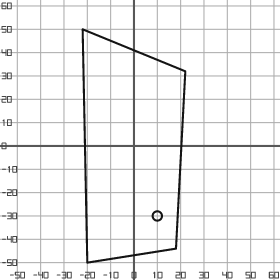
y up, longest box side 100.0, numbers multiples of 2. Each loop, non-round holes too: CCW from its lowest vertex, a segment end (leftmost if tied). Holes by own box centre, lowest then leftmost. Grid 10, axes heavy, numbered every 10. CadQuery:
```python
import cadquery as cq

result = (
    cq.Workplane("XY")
    .moveTo(-20.0, -50.0)
    .lineTo(18.0, -44.0)
    .lineTo(22.0, 32.0)
    .lineTo(-22.0, 50.0)
    .close()
    .moveTo(10.0, -30.0)
    .circle(2.0)
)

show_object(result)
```